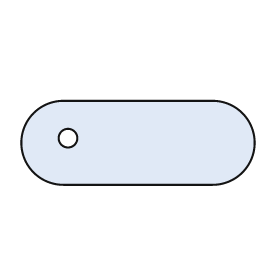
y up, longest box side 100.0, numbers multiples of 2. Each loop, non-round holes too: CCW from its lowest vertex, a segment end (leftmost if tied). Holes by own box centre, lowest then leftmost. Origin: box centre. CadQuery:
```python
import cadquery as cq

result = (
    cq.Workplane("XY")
    .moveTo(-32.0, -18.0)
    .lineTo(32.0, -18.0)
    .threePointArc((50.0, 0.0), (32.0, 18.0))
    .lineTo(-32.0, 18.0)
    .threePointArc((-50.0, 0.0), (-32.0, -18.0))
    .close()
    .moveTo(-30.0, 2.0)
    .circle(4.0)
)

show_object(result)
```